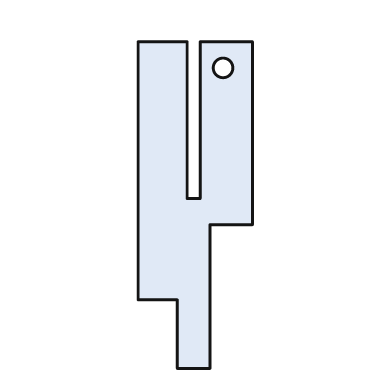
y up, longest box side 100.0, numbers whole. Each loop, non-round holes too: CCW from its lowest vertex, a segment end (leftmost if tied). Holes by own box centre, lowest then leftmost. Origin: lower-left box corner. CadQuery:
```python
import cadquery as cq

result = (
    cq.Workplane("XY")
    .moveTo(12.0, 0.0)
    .lineTo(22.0, 0.0)
    .lineTo(22.0, 44.0)
    .lineTo(35.0, 44.0)
    .lineTo(35.0, 100.0)
    .lineTo(19.0, 100.0)
    .lineTo(19.0, 52.0)
    .lineTo(15.0, 52.0)
    .lineTo(15.0, 100.0)
    .lineTo(0.0, 100.0)
    .lineTo(0.0, 21.0)
    .lineTo(12.0, 21.0)
    .close()
    .moveTo(26.0, 92.0)
    .circle(3.0)
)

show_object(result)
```